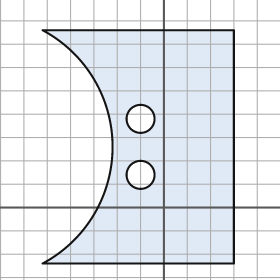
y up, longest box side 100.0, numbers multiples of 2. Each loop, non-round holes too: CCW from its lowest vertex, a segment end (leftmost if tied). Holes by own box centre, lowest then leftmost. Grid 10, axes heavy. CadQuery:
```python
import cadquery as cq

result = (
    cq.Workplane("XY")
    .moveTo(-52.0, -24.0)
    .lineTo(30.0, -24.0)
    .lineTo(30.0, 76.0)
    .lineTo(-52.0, 76.0)
    .threePointArc((-22.0, 26.0), (-52.0, -24.0))
    .close()
    .moveTo(-10.0, 14.0)
    .circle(6.0)
    .moveTo(-10.0, 38.0)
    .circle(6.0)
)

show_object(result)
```